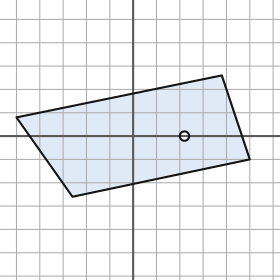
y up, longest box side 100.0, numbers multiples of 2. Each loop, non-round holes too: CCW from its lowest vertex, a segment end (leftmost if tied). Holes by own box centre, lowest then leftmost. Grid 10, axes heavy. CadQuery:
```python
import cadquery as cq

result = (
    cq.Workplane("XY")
    .moveTo(-26.0, -26.0)
    .lineTo(50.0, -10.0)
    .lineTo(38.0, 26.0)
    .lineTo(-50.0, 8.0)
    .close()
    .moveTo(22.0, 0.0)
    .circle(2.0)
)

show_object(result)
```